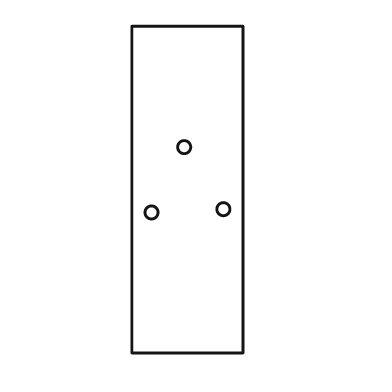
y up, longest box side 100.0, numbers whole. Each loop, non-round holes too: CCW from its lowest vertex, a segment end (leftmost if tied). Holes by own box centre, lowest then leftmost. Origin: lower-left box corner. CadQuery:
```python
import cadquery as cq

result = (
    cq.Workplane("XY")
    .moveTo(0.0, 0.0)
    .lineTo(34.0, 0.0)
    .lineTo(34.0, 100.0)
    .lineTo(0.0, 100.0)
    .close()
    .moveTo(6.0, 43.0)
    .circle(2.0)
    .moveTo(28.0, 44.0)
    .circle(2.0)
    .moveTo(16.0, 63.0)
    .circle(2.0)
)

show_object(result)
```